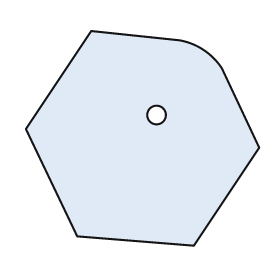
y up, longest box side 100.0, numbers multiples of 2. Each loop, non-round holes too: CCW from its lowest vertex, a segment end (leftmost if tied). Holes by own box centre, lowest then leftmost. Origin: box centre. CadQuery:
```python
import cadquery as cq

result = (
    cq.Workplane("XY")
    .moveTo(22.0, -46.0)
    .lineTo(50.0, -4.0)
    .lineTo(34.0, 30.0)
    .threePointArc((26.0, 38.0), (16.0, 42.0))
    .lineTo(-22.0, 46.0)
    .lineTo(-50.0, 4.0)
    .lineTo(-28.0, -42.0)
    .close()
    .moveTo(6.0, 10.0)
    .circle(4.0)
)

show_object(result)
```